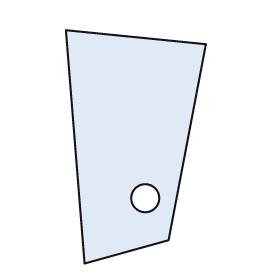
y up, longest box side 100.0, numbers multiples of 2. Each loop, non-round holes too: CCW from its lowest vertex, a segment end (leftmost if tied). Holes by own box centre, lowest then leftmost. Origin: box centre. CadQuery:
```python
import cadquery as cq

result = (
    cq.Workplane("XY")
    .moveTo(-22.0, -50.0)
    .lineTo(14.0, -40.0)
    .lineTo(30.0, 44.0)
    .lineTo(-30.0, 50.0)
    .close()
    .moveTo(4.0, -22.0)
    .circle(6.0)
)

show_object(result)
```